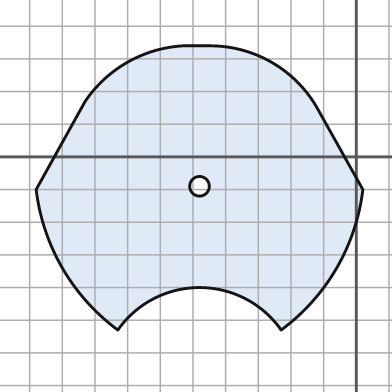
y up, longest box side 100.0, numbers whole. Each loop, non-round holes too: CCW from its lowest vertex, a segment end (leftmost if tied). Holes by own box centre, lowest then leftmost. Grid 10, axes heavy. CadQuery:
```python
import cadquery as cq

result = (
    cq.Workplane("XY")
    .moveTo(-73.0, -53.0)
    .threePointArc((-48.0, -40.0), (-23.0, -53.0))
    .threePointArc((-6.0, -34.0), (2.0, -10.0))
    .lineTo(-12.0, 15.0)
    .threePointArc((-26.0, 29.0), (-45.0, 34.0))
    .lineTo(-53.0, 34.0)
    .threePointArc((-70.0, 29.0), (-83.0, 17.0))
    .lineTo(-98.0, -10.0)
    .threePointArc((-90.0, -34.0), (-73.0, -53.0))
    .close()
    .moveTo(-48.0, -9.0)
    .circle(3.0)
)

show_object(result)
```